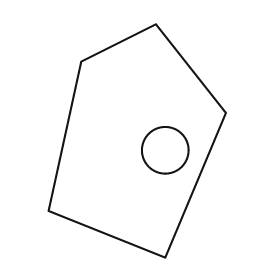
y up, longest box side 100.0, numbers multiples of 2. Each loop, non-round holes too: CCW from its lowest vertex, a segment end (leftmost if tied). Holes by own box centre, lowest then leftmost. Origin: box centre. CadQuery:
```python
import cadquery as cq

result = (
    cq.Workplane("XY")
    .moveTo(12.0, -50.0)
    .lineTo(38.0, 12.0)
    .lineTo(8.0, 50.0)
    .lineTo(-24.0, 34.0)
    .lineTo(-38.0, -30.0)
    .close()
    .moveTo(12.0, -4.0)
    .circle(10.0)
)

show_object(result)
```